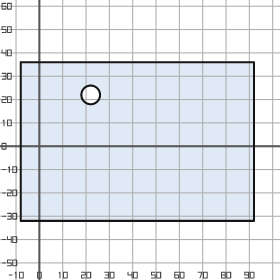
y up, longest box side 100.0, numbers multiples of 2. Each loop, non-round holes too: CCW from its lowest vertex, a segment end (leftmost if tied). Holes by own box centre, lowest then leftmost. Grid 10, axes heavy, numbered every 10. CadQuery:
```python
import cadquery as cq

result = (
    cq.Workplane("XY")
    .moveTo(-8.0, -32.0)
    .lineTo(92.0, -32.0)
    .lineTo(92.0, 36.0)
    .lineTo(-8.0, 36.0)
    .close()
    .moveTo(22.0, 22.0)
    .circle(4.0)
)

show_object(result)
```